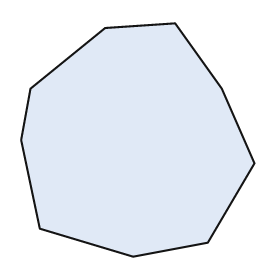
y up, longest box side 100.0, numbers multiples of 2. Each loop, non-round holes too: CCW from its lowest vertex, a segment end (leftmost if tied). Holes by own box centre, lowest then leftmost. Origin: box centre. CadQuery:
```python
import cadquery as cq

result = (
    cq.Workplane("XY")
    .moveTo(-2.0, -50.0)
    .lineTo(30.0, -44.0)
    .lineTo(50.0, -10.0)
    .lineTo(36.0, 22.0)
    .lineTo(16.0, 50.0)
    .lineTo(-14.0, 48.0)
    .lineTo(-46.0, 22.0)
    .lineTo(-50.0, 0.0)
    .lineTo(-42.0, -38.0)
    .close()
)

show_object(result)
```